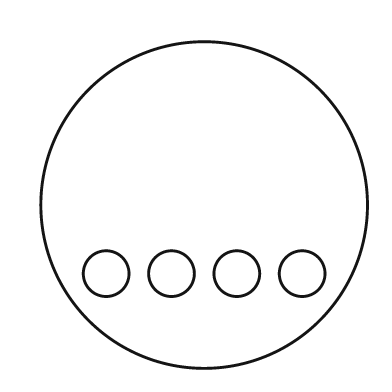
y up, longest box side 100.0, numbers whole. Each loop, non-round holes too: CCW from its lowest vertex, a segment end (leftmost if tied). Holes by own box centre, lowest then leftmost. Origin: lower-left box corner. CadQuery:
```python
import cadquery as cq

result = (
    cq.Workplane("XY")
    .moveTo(50.0, 50.0)
    .circle(50.0)
    .moveTo(20.0, 29.0)
    .circle(7.0)
    .moveTo(40.0, 29.0)
    .circle(7.0)
    .moveTo(60.0, 29.0)
    .circle(7.0)
    .moveTo(80.0, 29.0)
    .circle(7.0)
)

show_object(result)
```